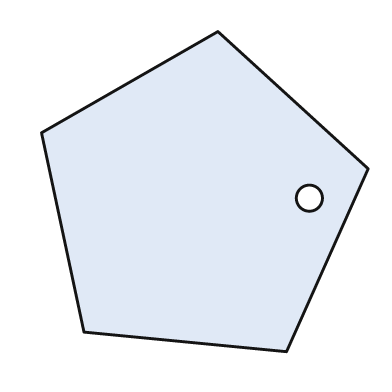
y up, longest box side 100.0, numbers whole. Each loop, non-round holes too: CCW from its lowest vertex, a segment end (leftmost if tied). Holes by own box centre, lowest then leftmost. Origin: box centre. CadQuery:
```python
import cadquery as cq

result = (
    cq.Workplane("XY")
    .moveTo(25.0, -49.0)
    .lineTo(50.0, 7.0)
    .lineTo(4.0, 49.0)
    .lineTo(-50.0, 18.0)
    .lineTo(-37.0, -43.0)
    .close()
    .moveTo(32.0, -2.0)
    .circle(4.0)
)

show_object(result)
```